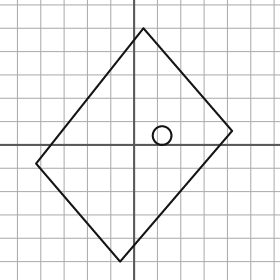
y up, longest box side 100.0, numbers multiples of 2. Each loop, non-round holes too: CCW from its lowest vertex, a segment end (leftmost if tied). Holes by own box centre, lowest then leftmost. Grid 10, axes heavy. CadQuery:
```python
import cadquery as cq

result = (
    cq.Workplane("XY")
    .moveTo(-6.0, -50.0)
    .lineTo(42.0, 6.0)
    .lineTo(4.0, 50.0)
    .lineTo(-42.0, -8.0)
    .close()
    .moveTo(12.0, 4.0)
    .circle(4.0)
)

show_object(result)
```